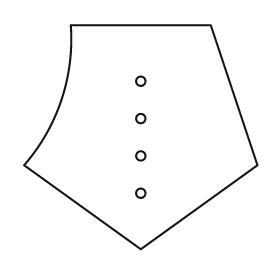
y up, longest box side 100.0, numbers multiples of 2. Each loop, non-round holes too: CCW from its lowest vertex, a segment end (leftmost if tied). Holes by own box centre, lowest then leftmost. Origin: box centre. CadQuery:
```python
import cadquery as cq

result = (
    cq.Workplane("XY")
    .moveTo(0.0, -48.0)
    .lineTo(50.0, -12.0)
    .lineTo(30.0, 48.0)
    .lineTo(-30.0, 48.0)
    .threePointArc((-34.0, 16.0), (-50.0, -12.0))
    .close()
    .moveTo(0.0, -24.0)
    .circle(2.0)
    .moveTo(0.0, -8.0)
    .circle(2.0)
    .moveTo(0.0, 8.0)
    .circle(2.0)
    .moveTo(0.0, 24.0)
    .circle(2.0)
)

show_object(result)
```